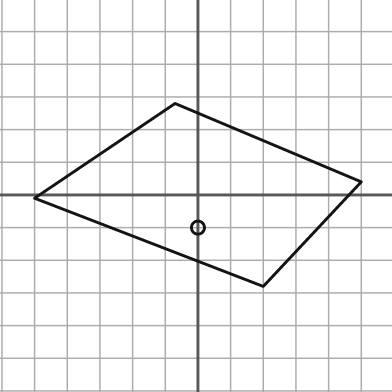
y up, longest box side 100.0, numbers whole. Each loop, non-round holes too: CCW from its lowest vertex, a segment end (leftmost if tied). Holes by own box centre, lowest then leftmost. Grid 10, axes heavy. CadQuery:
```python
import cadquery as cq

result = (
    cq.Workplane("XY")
    .moveTo(20.0, -28.0)
    .lineTo(50.0, 4.0)
    .lineTo(-7.0, 28.0)
    .lineTo(-50.0, -1.0)
    .close()
    .moveTo(0.0, -10.0)
    .circle(2.0)
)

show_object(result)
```